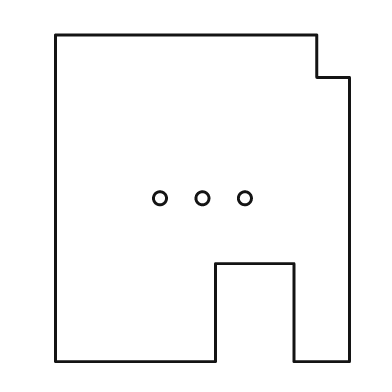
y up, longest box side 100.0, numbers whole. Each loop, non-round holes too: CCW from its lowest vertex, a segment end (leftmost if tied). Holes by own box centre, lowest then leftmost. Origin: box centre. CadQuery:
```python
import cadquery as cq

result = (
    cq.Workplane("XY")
    .moveTo(-45.0, -50.0)
    .lineTo(4.0, -50.0)
    .lineTo(4.0, -20.0)
    .lineTo(28.0, -20.0)
    .lineTo(28.0, -50.0)
    .lineTo(45.0, -50.0)
    .lineTo(45.0, 37.0)
    .lineTo(35.0, 37.0)
    .lineTo(35.0, 50.0)
    .lineTo(-45.0, 50.0)
    .close()
    .moveTo(-13.0, 0.0)
    .circle(2.0)
    .moveTo(0.0, 0.0)
    .circle(2.0)
    .moveTo(13.0, 0.0)
    .circle(2.0)
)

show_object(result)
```